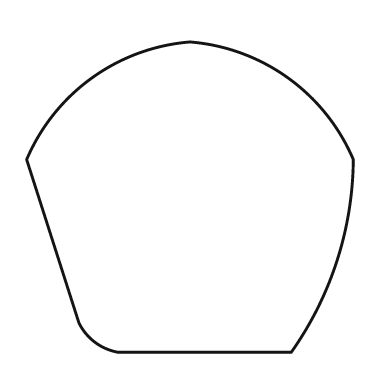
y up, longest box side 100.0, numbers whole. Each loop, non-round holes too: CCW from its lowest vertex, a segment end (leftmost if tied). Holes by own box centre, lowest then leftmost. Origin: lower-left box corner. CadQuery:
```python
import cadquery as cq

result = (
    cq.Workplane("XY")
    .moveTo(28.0, 0.0)
    .lineTo(81.0, 0.0)
    .threePointArc((95.0, 28.0), (100.0, 59.0))
    .threePointArc((80.0, 84.0), (50.0, 95.0))
    .threePointArc((20.0, 84.0), (0.0, 59.0))
    .lineTo(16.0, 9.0)
    .threePointArc((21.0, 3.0), (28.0, 0.0))
    .close()
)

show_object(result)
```